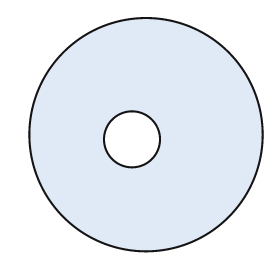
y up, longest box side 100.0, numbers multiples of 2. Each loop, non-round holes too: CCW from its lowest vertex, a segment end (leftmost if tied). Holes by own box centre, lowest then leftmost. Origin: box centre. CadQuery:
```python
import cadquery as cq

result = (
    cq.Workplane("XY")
    .moveTo(0.0, 0.0)
    .circle(50.0)
    .moveTo(-6.0, -2.0)
    .circle(12.0)
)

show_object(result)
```